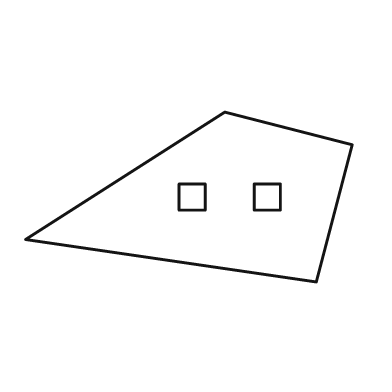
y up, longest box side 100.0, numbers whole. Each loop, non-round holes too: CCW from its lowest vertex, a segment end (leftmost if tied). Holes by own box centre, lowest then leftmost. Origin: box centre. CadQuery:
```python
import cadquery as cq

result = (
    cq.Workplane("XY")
    .moveTo(39.0, -26.0)
    .lineTo(50.0, 16.0)
    .lineTo(11.0, 26.0)
    .lineTo(-50.0, -13.0)
    .close()
    .moveTo(-3.0, -4.0)
    .lineTo(5.0, -4.0)
    .lineTo(5.0, 4.0)
    .lineTo(-3.0, 4.0)
    .close()
    .moveTo(20.0, -4.0)
    .lineTo(28.0, -4.0)
    .lineTo(28.0, 4.0)
    .lineTo(20.0, 4.0)
    .close()
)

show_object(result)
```